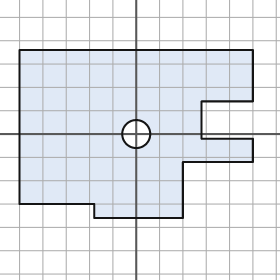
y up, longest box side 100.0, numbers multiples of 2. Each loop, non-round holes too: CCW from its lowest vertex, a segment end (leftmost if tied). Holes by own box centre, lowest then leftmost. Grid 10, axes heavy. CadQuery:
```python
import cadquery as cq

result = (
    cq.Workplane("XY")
    .moveTo(-18.0, -36.0)
    .lineTo(20.0, -36.0)
    .lineTo(20.0, -12.0)
    .lineTo(50.0, -12.0)
    .lineTo(50.0, -2.0)
    .lineTo(28.0, -2.0)
    .lineTo(28.0, 14.0)
    .lineTo(50.0, 14.0)
    .lineTo(50.0, 36.0)
    .lineTo(-50.0, 36.0)
    .lineTo(-50.0, -30.0)
    .lineTo(-18.0, -30.0)
    .close()
    .moveTo(0.0, 0.0)
    .circle(6.0)
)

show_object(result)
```